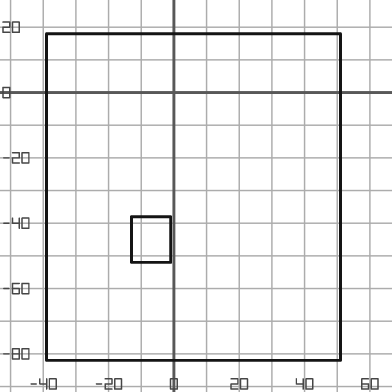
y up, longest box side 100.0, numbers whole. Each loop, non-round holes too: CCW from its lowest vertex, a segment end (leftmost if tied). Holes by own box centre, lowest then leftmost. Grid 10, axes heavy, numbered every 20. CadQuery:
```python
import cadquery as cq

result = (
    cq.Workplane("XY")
    .moveTo(-39.0, -82.0)
    .lineTo(51.0, -82.0)
    .lineTo(51.0, 18.0)
    .lineTo(-39.0, 18.0)
    .close()
    .moveTo(-13.0, -52.0)
    .lineTo(-1.0, -52.0)
    .lineTo(-1.0, -38.0)
    .lineTo(-13.0, -38.0)
    .close()
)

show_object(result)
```